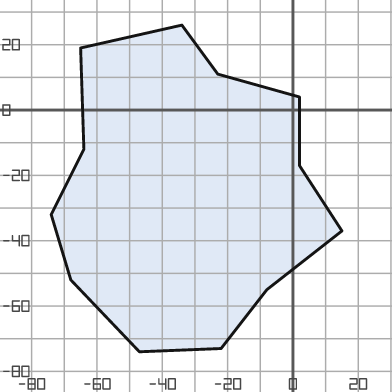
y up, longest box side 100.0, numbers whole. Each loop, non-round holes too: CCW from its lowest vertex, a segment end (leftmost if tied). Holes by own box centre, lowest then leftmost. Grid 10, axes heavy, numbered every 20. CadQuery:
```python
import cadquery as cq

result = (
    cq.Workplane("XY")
    .moveTo(-47.0, -74.0)
    .lineTo(-22.0, -73.0)
    .lineTo(-8.0, -55.0)
    .lineTo(15.0, -37.0)
    .lineTo(2.0, -17.0)
    .lineTo(2.0, 4.0)
    .lineTo(-23.0, 11.0)
    .lineTo(-34.0, 26.0)
    .lineTo(-65.0, 19.0)
    .lineTo(-64.0, -12.0)
    .lineTo(-74.0, -32.0)
    .lineTo(-68.0, -52.0)
    .close()
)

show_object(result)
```